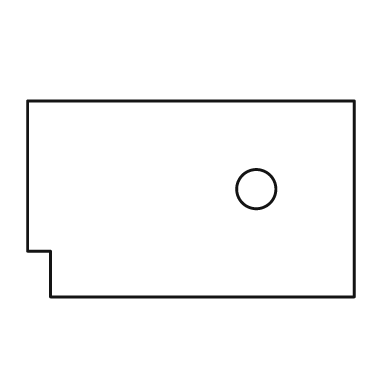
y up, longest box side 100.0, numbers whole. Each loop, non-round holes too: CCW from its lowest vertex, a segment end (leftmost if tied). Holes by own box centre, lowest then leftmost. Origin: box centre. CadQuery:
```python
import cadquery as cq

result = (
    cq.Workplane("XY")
    .moveTo(-43.0, -30.0)
    .lineTo(50.0, -30.0)
    .lineTo(50.0, 30.0)
    .lineTo(-50.0, 30.0)
    .lineTo(-50.0, -16.0)
    .lineTo(-43.0, -16.0)
    .close()
    .moveTo(20.0, 3.0)
    .circle(6.0)
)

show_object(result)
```